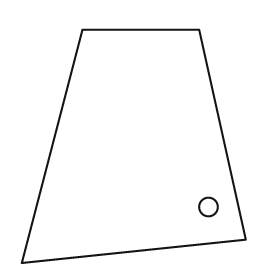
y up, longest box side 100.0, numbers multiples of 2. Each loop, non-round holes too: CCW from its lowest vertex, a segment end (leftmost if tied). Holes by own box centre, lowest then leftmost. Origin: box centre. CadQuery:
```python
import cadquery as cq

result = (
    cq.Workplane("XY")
    .moveTo(-48.0, -50.0)
    .lineTo(48.0, -40.0)
    .lineTo(28.0, 50.0)
    .lineTo(-22.0, 50.0)
    .close()
    .moveTo(32.0, -26.0)
    .circle(4.0)
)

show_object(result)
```